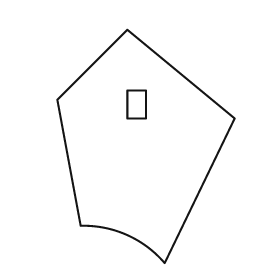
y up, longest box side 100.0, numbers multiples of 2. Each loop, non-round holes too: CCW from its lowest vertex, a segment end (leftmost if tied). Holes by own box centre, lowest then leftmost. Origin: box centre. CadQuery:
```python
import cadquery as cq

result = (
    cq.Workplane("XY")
    .moveTo(8.0, -50.0)
    .lineTo(38.0, 12.0)
    .lineTo(-8.0, 50.0)
    .lineTo(-38.0, 20.0)
    .lineTo(-28.0, -34.0)
    .threePointArc((-8.0, -38.0), (8.0, -50.0))
    .close()
    .moveTo(-8.0, 12.0)
    .lineTo(0.0, 12.0)
    .lineTo(0.0, 24.0)
    .lineTo(-8.0, 24.0)
    .close()
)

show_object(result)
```